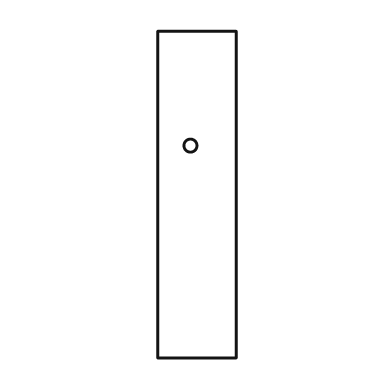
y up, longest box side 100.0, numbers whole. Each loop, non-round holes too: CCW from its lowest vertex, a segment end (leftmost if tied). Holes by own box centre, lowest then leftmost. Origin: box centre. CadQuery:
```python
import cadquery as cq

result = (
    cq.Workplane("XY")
    .moveTo(-12.0, -50.0)
    .lineTo(12.0, -50.0)
    .lineTo(12.0, 50.0)
    .lineTo(-12.0, 50.0)
    .close()
    .moveTo(-2.0, 15.0)
    .circle(2.0)
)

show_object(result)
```